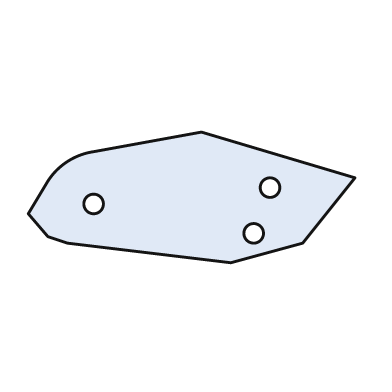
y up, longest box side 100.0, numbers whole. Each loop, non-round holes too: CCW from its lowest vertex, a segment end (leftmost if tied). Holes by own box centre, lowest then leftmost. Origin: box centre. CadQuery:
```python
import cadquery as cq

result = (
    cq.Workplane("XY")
    .moveTo(12.0, -20.0)
    .lineTo(34.0, -14.0)
    .lineTo(50.0, 6.0)
    .lineTo(3.0, 20.0)
    .lineTo(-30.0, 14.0)
    .threePointArc((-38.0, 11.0), (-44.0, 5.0))
    .lineTo(-50.0, -5.0)
    .lineTo(-44.0, -12.0)
    .lineTo(-38.0, -14.0)
    .close()
    .moveTo(19.0, -11.0)
    .circle(3.0)
    .moveTo(-30.0, -2.0)
    .circle(3.0)
    .moveTo(24.0, 3.0)
    .circle(3.0)
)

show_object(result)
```